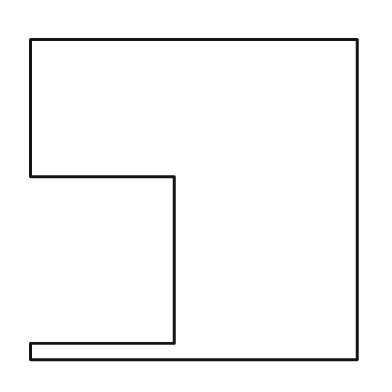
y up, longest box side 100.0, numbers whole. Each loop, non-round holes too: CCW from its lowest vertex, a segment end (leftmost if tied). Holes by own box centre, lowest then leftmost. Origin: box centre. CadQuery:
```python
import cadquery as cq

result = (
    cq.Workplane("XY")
    .moveTo(-50.0, -49.0)
    .lineTo(50.0, -49.0)
    .lineTo(50.0, 49.0)
    .lineTo(-50.0, 49.0)
    .lineTo(-50.0, 7.0)
    .lineTo(-6.0, 7.0)
    .lineTo(-6.0, -44.0)
    .lineTo(-50.0, -44.0)
    .close()
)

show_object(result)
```